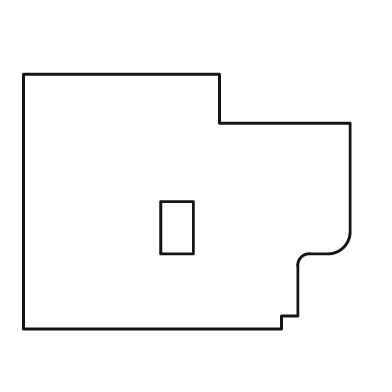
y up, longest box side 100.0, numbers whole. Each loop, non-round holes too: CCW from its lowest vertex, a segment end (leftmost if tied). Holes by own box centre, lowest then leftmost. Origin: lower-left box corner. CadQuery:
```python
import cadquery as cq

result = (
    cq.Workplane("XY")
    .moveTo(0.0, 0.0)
    .lineTo(79.0, 0.0)
    .lineTo(79.0, 4.0)
    .lineTo(84.0, 4.0)
    .lineTo(84.0, 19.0)
    .threePointArc((85.0, 22.0), (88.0, 23.0))
    .lineTo(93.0, 23.0)
    .threePointArc((98.0, 25.0), (100.0, 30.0))
    .lineTo(100.0, 63.0)
    .lineTo(60.0, 63.0)
    .lineTo(60.0, 78.0)
    .lineTo(0.0, 78.0)
    .close()
    .moveTo(42.0, 23.0)
    .lineTo(52.0, 23.0)
    .lineTo(52.0, 39.0)
    .lineTo(42.0, 39.0)
    .close()
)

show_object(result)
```